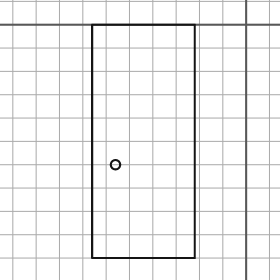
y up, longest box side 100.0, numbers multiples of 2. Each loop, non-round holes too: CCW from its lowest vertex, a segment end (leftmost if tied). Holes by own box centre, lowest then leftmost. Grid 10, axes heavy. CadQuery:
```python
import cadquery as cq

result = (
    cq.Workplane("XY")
    .moveTo(-66.0, -100.0)
    .lineTo(-22.0, -100.0)
    .lineTo(-22.0, 0.0)
    .lineTo(-66.0, 0.0)
    .close()
    .moveTo(-56.0, -60.0)
    .circle(2.0)
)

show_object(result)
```